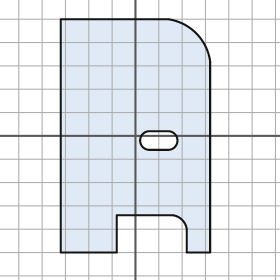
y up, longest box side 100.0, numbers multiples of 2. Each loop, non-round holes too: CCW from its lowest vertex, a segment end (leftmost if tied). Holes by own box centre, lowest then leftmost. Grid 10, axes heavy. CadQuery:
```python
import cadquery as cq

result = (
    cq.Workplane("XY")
    .moveTo(-32.0, -50.0)
    .lineTo(-8.0, -50.0)
    .lineTo(-8.0, -34.0)
    .lineTo(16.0, -34.0)
    .threePointArc((20.0, -36.0), (22.0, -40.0))
    .lineTo(22.0, -50.0)
    .lineTo(32.0, -50.0)
    .lineTo(32.0, 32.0)
    .threePointArc((26.0, 44.0), (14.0, 50.0))
    .lineTo(-32.0, 50.0)
    .close()
    .moveTo(6.0, -6.0)
    .lineTo(14.0, -6.0)
    .threePointArc((18.0, -2.0), (14.0, 2.0))
    .lineTo(6.0, 2.0)
    .threePointArc((2.0, -2.0), (6.0, -6.0))
    .close()
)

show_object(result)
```